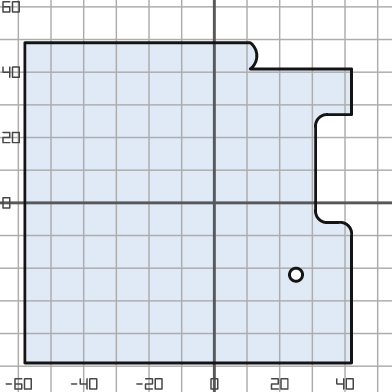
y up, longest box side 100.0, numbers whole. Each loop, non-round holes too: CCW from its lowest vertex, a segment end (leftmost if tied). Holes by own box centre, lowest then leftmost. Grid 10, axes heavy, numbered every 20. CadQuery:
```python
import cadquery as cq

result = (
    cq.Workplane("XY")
    .moveTo(-58.0, -49.0)
    .lineTo(42.0, -49.0)
    .lineTo(42.0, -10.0)
    .threePointArc((41.0, -7.0), (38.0, -6.0))
    .lineTo(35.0, -6.0)
    .threePointArc((32.0, -5.0), (31.0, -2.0))
    .lineTo(31.0, 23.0)
    .threePointArc((32.0, 26.0), (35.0, 27.0))
    .lineTo(42.0, 27.0)
    .lineTo(42.0, 41.0)
    .lineTo(11.0, 41.0)
    .threePointArc((13.0, 45.0), (11.0, 49.0))
    .lineTo(-58.0, 49.0)
    .close()
    .moveTo(25.0, -22.0)
    .circle(2.0)
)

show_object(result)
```